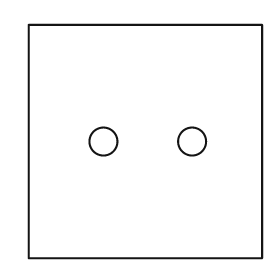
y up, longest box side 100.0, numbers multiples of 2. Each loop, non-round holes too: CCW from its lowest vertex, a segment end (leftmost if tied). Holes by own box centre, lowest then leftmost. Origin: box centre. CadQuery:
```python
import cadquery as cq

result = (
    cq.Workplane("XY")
    .moveTo(-50.0, -50.0)
    .lineTo(50.0, -50.0)
    .lineTo(50.0, 50.0)
    .lineTo(-50.0, 50.0)
    .close()
    .moveTo(-18.0, 0.0)
    .circle(6.0)
    .moveTo(20.0, 0.0)
    .circle(6.0)
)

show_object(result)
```